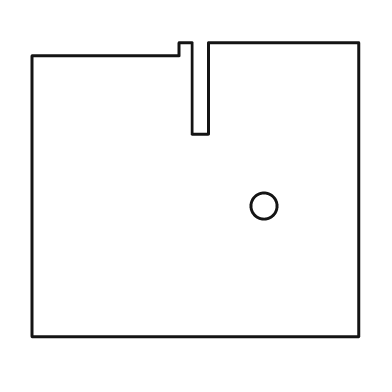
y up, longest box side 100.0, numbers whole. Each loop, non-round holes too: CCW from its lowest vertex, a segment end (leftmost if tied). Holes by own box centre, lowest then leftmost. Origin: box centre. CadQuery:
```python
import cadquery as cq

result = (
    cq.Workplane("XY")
    .moveTo(-50.0, -45.0)
    .lineTo(50.0, -45.0)
    .lineTo(50.0, 45.0)
    .lineTo(4.0, 45.0)
    .lineTo(4.0, 17.0)
    .lineTo(-1.0, 17.0)
    .lineTo(-1.0, 45.0)
    .lineTo(-5.0, 45.0)
    .lineTo(-5.0, 41.0)
    .lineTo(-50.0, 41.0)
    .close()
    .moveTo(21.0, -5.0)
    .circle(4.0)
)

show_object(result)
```